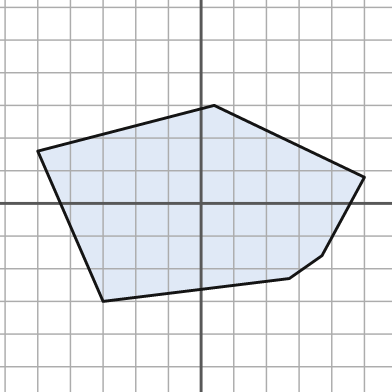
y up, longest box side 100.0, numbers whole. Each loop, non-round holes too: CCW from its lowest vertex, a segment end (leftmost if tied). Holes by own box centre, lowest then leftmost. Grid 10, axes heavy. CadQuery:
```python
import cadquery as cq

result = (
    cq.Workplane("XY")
    .moveTo(-30.0, -30.0)
    .lineTo(27.0, -23.0)
    .lineTo(37.0, -16.0)
    .lineTo(50.0, 8.0)
    .lineTo(4.0, 30.0)
    .lineTo(-50.0, 16.0)
    .close()
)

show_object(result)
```